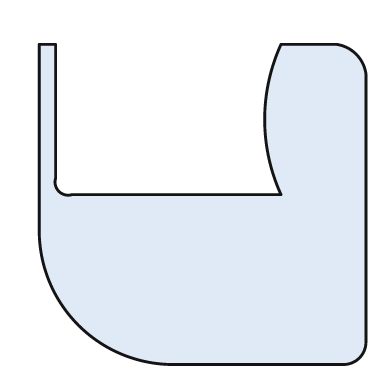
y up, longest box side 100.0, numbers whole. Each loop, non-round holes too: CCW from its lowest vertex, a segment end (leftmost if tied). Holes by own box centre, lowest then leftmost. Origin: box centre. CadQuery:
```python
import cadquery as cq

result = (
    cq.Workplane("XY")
    .moveTo(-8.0, -49.0)
    .lineTo(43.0, -49.0)
    .threePointArc((48.0, -47.0), (50.0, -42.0))
    .lineTo(50.0, 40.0)
    .threePointArc((47.0, 46.0), (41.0, 49.0))
    .lineTo(24.0, 49.0)
    .threePointArc((19.0, 26.0), (24.0, 3.0))
    .lineTo(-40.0, 3.0)
    .threePointArc((-44.0, 4.0), (-45.0, 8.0))
    .lineTo(-45.0, 49.0)
    .lineTo(-50.0, 49.0)
    .lineTo(-50.0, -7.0)
    .threePointArc((-38.0, -37.0), (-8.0, -49.0))
    .close()
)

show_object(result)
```